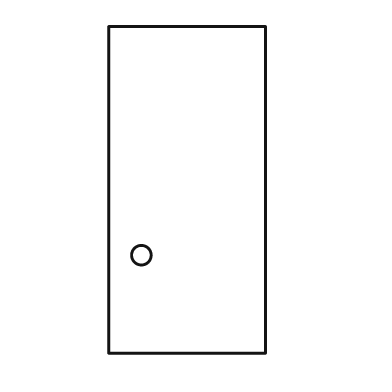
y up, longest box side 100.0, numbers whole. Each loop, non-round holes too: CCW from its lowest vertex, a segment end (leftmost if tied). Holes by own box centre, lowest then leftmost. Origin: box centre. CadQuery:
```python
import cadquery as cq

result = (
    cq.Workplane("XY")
    .moveTo(-24.0, -50.0)
    .lineTo(24.0, -50.0)
    .lineTo(24.0, 50.0)
    .lineTo(-24.0, 50.0)
    .close()
    .moveTo(-14.0, -20.0)
    .circle(3.0)
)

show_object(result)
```